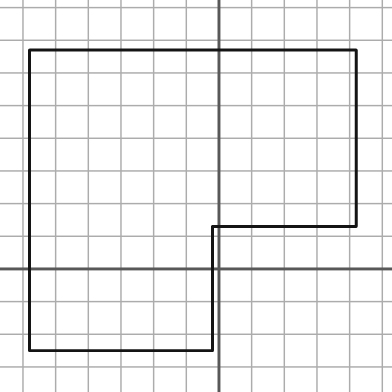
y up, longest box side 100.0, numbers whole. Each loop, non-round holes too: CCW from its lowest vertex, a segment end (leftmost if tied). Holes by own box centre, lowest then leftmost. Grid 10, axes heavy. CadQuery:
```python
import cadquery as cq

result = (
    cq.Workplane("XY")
    .moveTo(-58.0, -25.0)
    .lineTo(-2.0, -25.0)
    .lineTo(-2.0, 13.0)
    .lineTo(42.0, 13.0)
    .lineTo(42.0, 67.0)
    .lineTo(-58.0, 67.0)
    .close()
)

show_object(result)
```